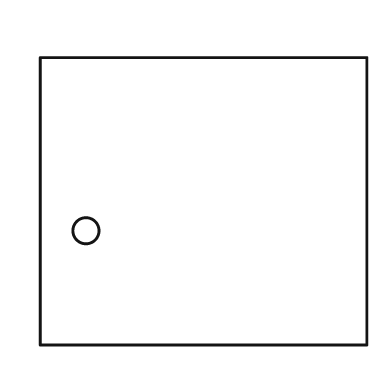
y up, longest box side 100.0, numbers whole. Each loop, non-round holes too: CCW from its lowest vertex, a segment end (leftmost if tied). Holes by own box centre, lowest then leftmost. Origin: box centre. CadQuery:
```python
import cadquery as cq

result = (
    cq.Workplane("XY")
    .moveTo(-50.0, -44.0)
    .lineTo(50.0, -44.0)
    .lineTo(50.0, 44.0)
    .lineTo(-50.0, 44.0)
    .close()
    .moveTo(-36.0, -9.0)
    .circle(4.0)
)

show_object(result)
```